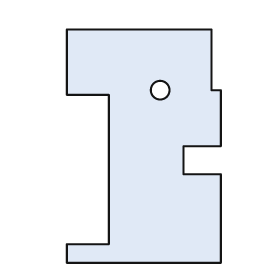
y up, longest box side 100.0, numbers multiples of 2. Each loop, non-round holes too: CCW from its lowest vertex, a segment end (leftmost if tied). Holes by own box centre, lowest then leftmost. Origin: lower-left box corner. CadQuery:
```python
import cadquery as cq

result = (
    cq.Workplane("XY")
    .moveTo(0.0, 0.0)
    .lineTo(66.0, 0.0)
    .lineTo(66.0, 38.0)
    .lineTo(50.0, 38.0)
    .lineTo(50.0, 50.0)
    .lineTo(66.0, 50.0)
    .lineTo(66.0, 74.0)
    .lineTo(62.0, 74.0)
    .lineTo(62.0, 100.0)
    .lineTo(0.0, 100.0)
    .lineTo(0.0, 72.0)
    .lineTo(18.0, 72.0)
    .lineTo(18.0, 8.0)
    .lineTo(0.0, 8.0)
    .close()
    .moveTo(40.0, 74.0)
    .circle(4.0)
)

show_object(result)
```